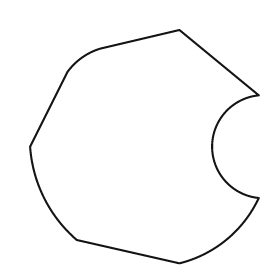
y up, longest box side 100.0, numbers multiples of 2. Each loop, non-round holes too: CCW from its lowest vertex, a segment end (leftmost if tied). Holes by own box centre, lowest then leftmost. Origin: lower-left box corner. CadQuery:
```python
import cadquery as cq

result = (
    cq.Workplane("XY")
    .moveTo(64.0, 0.0)
    .threePointArc((84.0, 10.0), (98.0, 28.0))
    .threePointArc((78.0, 50.0), (98.0, 72.0))
    .lineTo(64.0, 100.0)
    .lineTo(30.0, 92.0)
    .threePointArc((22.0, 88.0), (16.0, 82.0))
    .lineTo(0.0, 50.0)
    .threePointArc((6.0, 28.0), (20.0, 10.0))
    .close()
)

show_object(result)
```